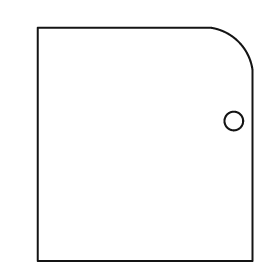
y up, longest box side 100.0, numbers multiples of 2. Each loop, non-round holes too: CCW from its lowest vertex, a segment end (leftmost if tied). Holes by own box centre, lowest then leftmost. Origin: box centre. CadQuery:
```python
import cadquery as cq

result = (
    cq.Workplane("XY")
    .moveTo(-46.0, -50.0)
    .lineTo(46.0, -50.0)
    .lineTo(46.0, 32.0)
    .threePointArc((40.0, 44.0), (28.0, 50.0))
    .lineTo(-46.0, 50.0)
    .close()
    .moveTo(38.0, 10.0)
    .circle(4.0)
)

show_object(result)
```